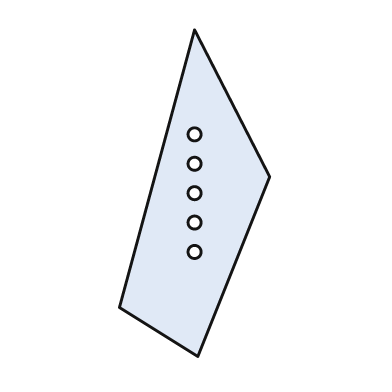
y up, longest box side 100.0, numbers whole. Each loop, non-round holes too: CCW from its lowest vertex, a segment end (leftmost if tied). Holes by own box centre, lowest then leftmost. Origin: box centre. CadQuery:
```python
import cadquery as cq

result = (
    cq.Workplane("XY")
    .moveTo(1.0, -50.0)
    .lineTo(23.0, 5.0)
    .lineTo(0.0, 50.0)
    .lineTo(-23.0, -35.0)
    .close()
    .moveTo(0.0, -18.0)
    .circle(2.0)
    .moveTo(0.0, -9.0)
    .circle(2.0)
    .moveTo(0.0, 0.0)
    .circle(2.0)
    .moveTo(0.0, 9.0)
    .circle(2.0)
    .moveTo(0.0, 18.0)
    .circle(2.0)
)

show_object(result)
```